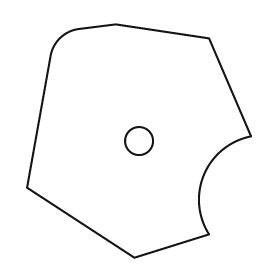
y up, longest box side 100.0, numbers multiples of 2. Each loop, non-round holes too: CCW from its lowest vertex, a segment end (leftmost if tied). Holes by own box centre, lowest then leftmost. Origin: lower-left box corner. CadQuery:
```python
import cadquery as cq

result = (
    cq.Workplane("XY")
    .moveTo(46.0, 0.0)
    .lineTo(78.0, 10.0)
    .threePointArc((76.0, 36.0), (96.0, 52.0))
    .lineTo(78.0, 94.0)
    .lineTo(38.0, 100.0)
    .lineTo(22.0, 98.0)
    .threePointArc((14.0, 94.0), (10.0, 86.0))
    .lineTo(0.0, 30.0)
    .close()
    .moveTo(48.0, 50.0)
    .circle(6.0)
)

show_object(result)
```